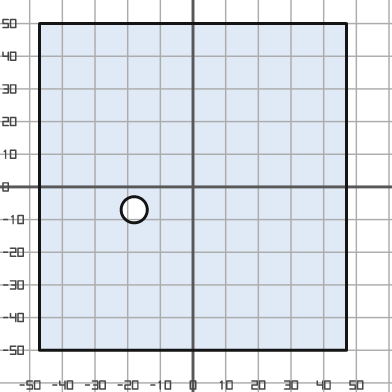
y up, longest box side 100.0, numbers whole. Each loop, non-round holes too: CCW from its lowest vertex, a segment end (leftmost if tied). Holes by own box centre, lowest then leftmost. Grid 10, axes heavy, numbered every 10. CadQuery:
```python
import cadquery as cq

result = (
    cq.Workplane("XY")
    .moveTo(-47.0, -50.0)
    .lineTo(47.0, -50.0)
    .lineTo(47.0, 50.0)
    .lineTo(-47.0, 50.0)
    .close()
    .moveTo(-18.0, -7.0)
    .circle(4.0)
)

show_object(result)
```